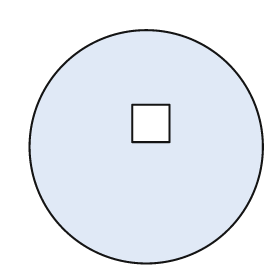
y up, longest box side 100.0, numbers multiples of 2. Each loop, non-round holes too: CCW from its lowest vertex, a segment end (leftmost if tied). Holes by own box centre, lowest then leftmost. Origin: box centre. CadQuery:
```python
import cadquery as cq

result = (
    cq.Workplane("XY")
    .moveTo(0.0, 0.0)
    .circle(50.0)
    .moveTo(-6.0, 2.0)
    .lineTo(10.0, 2.0)
    .lineTo(10.0, 18.0)
    .lineTo(-6.0, 18.0)
    .close()
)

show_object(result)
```